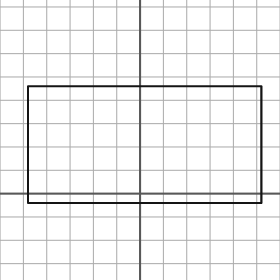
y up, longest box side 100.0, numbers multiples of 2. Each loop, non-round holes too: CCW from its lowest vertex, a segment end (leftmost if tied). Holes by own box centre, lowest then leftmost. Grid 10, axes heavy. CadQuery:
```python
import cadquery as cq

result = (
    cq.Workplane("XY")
    .moveTo(-48.0, -4.0)
    .lineTo(52.0, -4.0)
    .lineTo(52.0, 46.0)
    .lineTo(-48.0, 46.0)
    .close()
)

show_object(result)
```